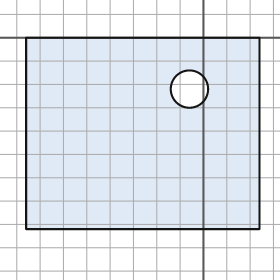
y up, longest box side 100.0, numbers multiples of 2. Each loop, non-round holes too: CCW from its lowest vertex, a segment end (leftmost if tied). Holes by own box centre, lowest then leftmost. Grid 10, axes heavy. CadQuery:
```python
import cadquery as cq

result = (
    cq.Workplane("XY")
    .moveTo(-76.0, -82.0)
    .lineTo(24.0, -82.0)
    .lineTo(24.0, 0.0)
    .lineTo(-76.0, 0.0)
    .close()
    .moveTo(-6.0, -22.0)
    .circle(8.0)
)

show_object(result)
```